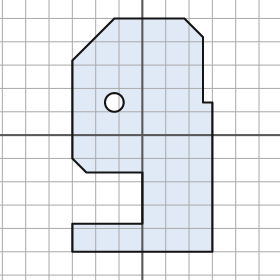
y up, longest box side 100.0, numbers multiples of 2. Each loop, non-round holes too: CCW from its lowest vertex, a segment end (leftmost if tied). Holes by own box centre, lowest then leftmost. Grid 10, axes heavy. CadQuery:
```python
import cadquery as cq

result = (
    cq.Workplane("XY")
    .moveTo(-30.0, -50.0)
    .lineTo(30.0, -50.0)
    .lineTo(30.0, 14.0)
    .lineTo(26.0, 14.0)
    .lineTo(26.0, 42.0)
    .lineTo(18.0, 50.0)
    .lineTo(-12.0, 50.0)
    .lineTo(-30.0, 32.0)
    .lineTo(-30.0, -10.0)
    .lineTo(-24.0, -16.0)
    .lineTo(0.0, -16.0)
    .lineTo(0.0, -38.0)
    .lineTo(-30.0, -38.0)
    .close()
    .moveTo(-12.0, 14.0)
    .circle(4.0)
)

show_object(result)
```